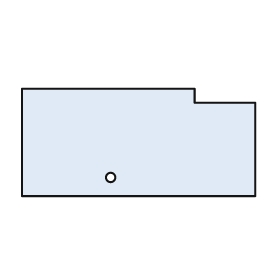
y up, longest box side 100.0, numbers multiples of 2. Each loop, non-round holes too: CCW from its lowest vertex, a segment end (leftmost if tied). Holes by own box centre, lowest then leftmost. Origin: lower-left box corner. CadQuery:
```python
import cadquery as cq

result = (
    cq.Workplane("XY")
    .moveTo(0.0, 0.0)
    .lineTo(100.0, 0.0)
    .lineTo(100.0, 40.0)
    .lineTo(74.0, 40.0)
    .lineTo(74.0, 46.0)
    .lineTo(0.0, 46.0)
    .close()
    .moveTo(38.0, 8.0)
    .circle(2.0)
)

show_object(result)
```